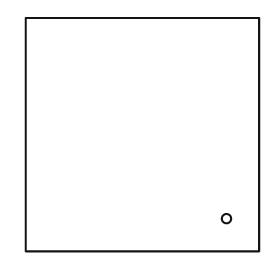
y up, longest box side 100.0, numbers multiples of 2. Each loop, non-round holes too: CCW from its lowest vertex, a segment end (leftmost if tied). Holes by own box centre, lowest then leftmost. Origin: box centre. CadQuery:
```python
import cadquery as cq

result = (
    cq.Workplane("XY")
    .moveTo(-50.0, -50.0)
    .lineTo(50.0, -50.0)
    .lineTo(50.0, 50.0)
    .lineTo(-50.0, 50.0)
    .close()
    .moveTo(36.0, -36.0)
    .circle(2.0)
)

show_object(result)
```